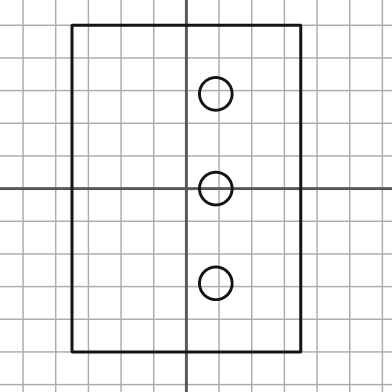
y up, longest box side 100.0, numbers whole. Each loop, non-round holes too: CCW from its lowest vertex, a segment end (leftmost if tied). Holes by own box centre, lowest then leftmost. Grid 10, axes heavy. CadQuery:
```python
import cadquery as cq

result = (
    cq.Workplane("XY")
    .moveTo(-35.0, -50.0)
    .lineTo(35.0, -50.0)
    .lineTo(35.0, 50.0)
    .lineTo(-35.0, 50.0)
    .close()
    .moveTo(9.0, -29.0)
    .circle(5.0)
    .moveTo(9.0, 0.0)
    .circle(5.0)
    .moveTo(9.0, 29.0)
    .circle(5.0)
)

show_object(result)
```